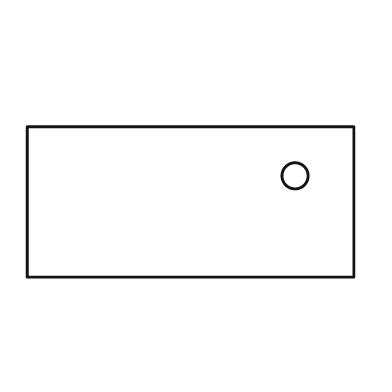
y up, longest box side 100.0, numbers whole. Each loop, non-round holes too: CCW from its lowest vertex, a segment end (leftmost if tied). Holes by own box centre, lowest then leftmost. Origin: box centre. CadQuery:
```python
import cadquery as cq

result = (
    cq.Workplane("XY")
    .moveTo(-50.0, -23.0)
    .lineTo(50.0, -23.0)
    .lineTo(50.0, 23.0)
    .lineTo(-50.0, 23.0)
    .close()
    .moveTo(32.0, 8.0)
    .circle(4.0)
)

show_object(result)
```